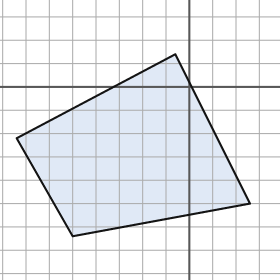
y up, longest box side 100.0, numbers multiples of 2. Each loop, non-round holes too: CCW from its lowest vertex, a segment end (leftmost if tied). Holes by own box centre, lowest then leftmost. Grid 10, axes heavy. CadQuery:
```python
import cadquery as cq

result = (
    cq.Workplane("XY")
    .moveTo(-50.0, -64.0)
    .lineTo(26.0, -50.0)
    .lineTo(-6.0, 14.0)
    .lineTo(-74.0, -22.0)
    .close()
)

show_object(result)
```